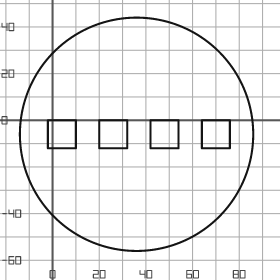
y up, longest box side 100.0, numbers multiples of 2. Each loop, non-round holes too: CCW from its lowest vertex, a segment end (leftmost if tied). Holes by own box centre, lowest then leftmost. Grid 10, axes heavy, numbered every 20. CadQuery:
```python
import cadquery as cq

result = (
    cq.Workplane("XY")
    .moveTo(36.0, -6.0)
    .circle(50.0)
    .moveTo(-2.0, -12.0)
    .lineTo(10.0, -12.0)
    .lineTo(10.0, 0.0)
    .lineTo(-2.0, 0.0)
    .close()
    .moveTo(20.0, -12.0)
    .lineTo(32.0, -12.0)
    .lineTo(32.0, 0.0)
    .lineTo(20.0, 0.0)
    .close()
    .moveTo(42.0, -12.0)
    .lineTo(54.0, -12.0)
    .lineTo(54.0, 0.0)
    .lineTo(42.0, 0.0)
    .close()
    .moveTo(64.0, -12.0)
    .lineTo(76.0, -12.0)
    .lineTo(76.0, 0.0)
    .lineTo(64.0, 0.0)
    .close()
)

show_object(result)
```